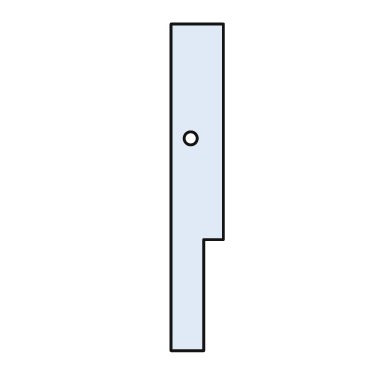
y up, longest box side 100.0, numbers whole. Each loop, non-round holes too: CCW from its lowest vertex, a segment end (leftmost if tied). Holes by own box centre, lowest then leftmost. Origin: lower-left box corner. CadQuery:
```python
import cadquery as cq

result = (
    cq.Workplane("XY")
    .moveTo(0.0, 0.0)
    .lineTo(10.0, 0.0)
    .lineTo(10.0, 34.0)
    .lineTo(16.0, 34.0)
    .lineTo(16.0, 100.0)
    .lineTo(0.0, 100.0)
    .close()
    .moveTo(6.0, 65.0)
    .circle(2.0)
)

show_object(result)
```